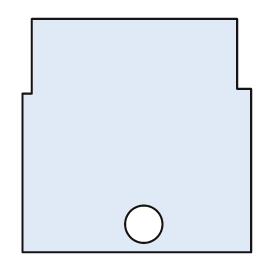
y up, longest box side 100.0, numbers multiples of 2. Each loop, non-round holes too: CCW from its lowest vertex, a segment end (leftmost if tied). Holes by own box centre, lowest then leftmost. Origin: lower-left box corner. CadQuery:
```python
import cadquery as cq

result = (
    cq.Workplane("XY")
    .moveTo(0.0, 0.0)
    .lineTo(98.0, 0.0)
    .lineTo(98.0, 70.0)
    .lineTo(92.0, 70.0)
    .lineTo(92.0, 100.0)
    .lineTo(4.0, 100.0)
    .lineTo(4.0, 68.0)
    .lineTo(0.0, 68.0)
    .close()
    .moveTo(52.0, 12.0)
    .circle(8.0)
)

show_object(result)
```